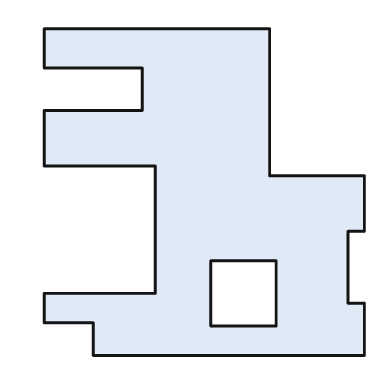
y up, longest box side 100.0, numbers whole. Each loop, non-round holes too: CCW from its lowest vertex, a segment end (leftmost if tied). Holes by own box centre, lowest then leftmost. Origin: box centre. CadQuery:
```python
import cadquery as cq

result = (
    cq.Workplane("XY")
    .moveTo(-34.0, -50.0)
    .lineTo(49.0, -50.0)
    .lineTo(49.0, -34.0)
    .lineTo(44.0, -34.0)
    .lineTo(44.0, -12.0)
    .lineTo(49.0, -12.0)
    .lineTo(49.0, 5.0)
    .lineTo(20.0, 5.0)
    .lineTo(20.0, 50.0)
    .lineTo(-49.0, 50.0)
    .lineTo(-49.0, 38.0)
    .lineTo(-19.0, 38.0)
    .lineTo(-19.0, 25.0)
    .lineTo(-49.0, 25.0)
    .lineTo(-49.0, 8.0)
    .lineTo(-15.0, 8.0)
    .lineTo(-15.0, -31.0)
    .lineTo(-49.0, -31.0)
    .lineTo(-49.0, -40.0)
    .lineTo(-34.0, -40.0)
    .close()
    .moveTo(2.0, -41.0)
    .lineTo(22.0, -41.0)
    .lineTo(22.0, -21.0)
    .lineTo(2.0, -21.0)
    .close()
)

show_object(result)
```